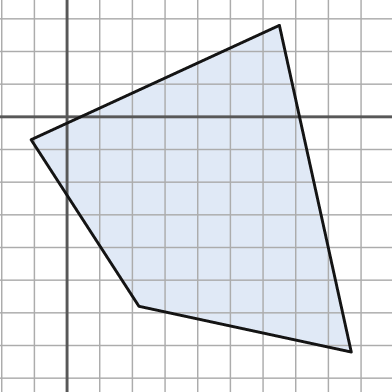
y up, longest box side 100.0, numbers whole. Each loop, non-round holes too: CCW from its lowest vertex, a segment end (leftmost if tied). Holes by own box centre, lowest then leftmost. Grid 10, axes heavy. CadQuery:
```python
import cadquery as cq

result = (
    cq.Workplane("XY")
    .moveTo(87.0, -72.0)
    .lineTo(65.0, 28.0)
    .lineTo(-11.0, -7.0)
    .lineTo(22.0, -58.0)
    .close()
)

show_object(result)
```